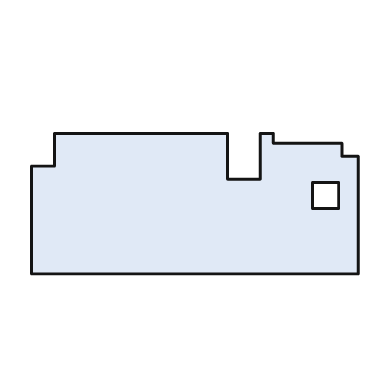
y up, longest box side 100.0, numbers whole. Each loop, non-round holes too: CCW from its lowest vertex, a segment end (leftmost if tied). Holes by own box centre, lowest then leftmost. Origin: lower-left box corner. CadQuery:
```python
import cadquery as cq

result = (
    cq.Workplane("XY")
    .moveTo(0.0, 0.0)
    .lineTo(100.0, 0.0)
    .lineTo(100.0, 36.0)
    .lineTo(95.0, 36.0)
    .lineTo(95.0, 40.0)
    .lineTo(74.0, 40.0)
    .lineTo(74.0, 43.0)
    .lineTo(70.0, 43.0)
    .lineTo(70.0, 29.0)
    .lineTo(60.0, 29.0)
    .lineTo(60.0, 43.0)
    .lineTo(7.0, 43.0)
    .lineTo(7.0, 33.0)
    .lineTo(0.0, 33.0)
    .close()
    .moveTo(86.0, 20.0)
    .lineTo(94.0, 20.0)
    .lineTo(94.0, 28.0)
    .lineTo(86.0, 28.0)
    .close()
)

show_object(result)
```